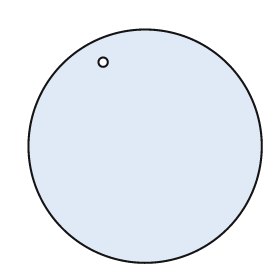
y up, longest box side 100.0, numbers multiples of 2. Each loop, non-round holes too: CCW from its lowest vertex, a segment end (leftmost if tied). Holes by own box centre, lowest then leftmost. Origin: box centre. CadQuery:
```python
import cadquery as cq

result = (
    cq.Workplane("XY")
    .moveTo(0.0, 0.0)
    .circle(50.0)
    .moveTo(-18.0, 36.0)
    .circle(2.0)
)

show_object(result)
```